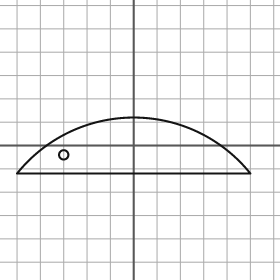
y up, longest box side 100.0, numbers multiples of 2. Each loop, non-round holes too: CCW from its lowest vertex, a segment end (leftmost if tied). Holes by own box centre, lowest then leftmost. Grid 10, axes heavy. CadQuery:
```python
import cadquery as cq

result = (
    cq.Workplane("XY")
    .moveTo(-50.0, -12.0)
    .lineTo(50.0, -12.0)
    .threePointArc((0.0, 12.0), (-50.0, -12.0))
    .close()
    .moveTo(-30.0, -4.0)
    .circle(2.0)
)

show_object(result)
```